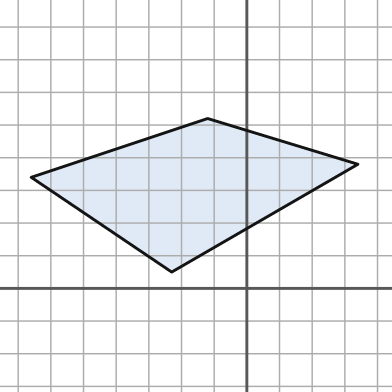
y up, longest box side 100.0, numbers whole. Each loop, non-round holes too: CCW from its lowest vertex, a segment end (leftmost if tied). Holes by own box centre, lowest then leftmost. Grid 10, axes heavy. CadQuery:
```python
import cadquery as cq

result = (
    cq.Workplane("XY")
    .moveTo(-23.0, 5.0)
    .lineTo(34.0, 38.0)
    .lineTo(-12.0, 52.0)
    .lineTo(-66.0, 34.0)
    .close()
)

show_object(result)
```